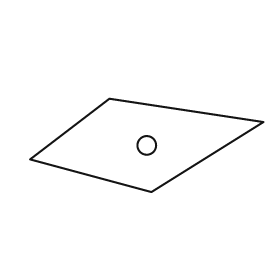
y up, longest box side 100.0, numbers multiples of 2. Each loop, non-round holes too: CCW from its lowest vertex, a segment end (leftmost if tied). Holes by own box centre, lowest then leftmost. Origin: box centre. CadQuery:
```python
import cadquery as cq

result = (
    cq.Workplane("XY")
    .moveTo(2.0, -20.0)
    .lineTo(50.0, 10.0)
    .lineTo(-16.0, 20.0)
    .lineTo(-50.0, -6.0)
    .close()
    .moveTo(0.0, 0.0)
    .circle(4.0)
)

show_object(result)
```